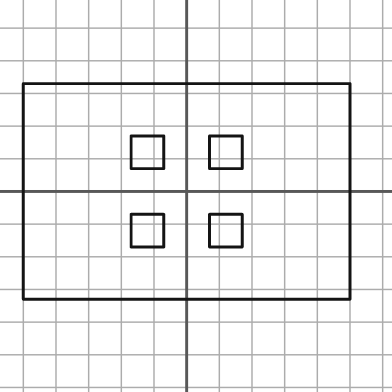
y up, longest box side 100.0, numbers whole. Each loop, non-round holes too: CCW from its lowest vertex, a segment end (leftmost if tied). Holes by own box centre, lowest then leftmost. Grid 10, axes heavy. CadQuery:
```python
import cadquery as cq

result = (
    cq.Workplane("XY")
    .moveTo(-50.0, -33.0)
    .lineTo(50.0, -33.0)
    .lineTo(50.0, 33.0)
    .lineTo(-50.0, 33.0)
    .close()
    .moveTo(-17.0, -17.0)
    .lineTo(-7.0, -17.0)
    .lineTo(-7.0, -7.0)
    .lineTo(-17.0, -7.0)
    .close()
    .moveTo(7.0, -17.0)
    .lineTo(17.0, -17.0)
    .lineTo(17.0, -7.0)
    .lineTo(7.0, -7.0)
    .close()
    .moveTo(-17.0, 7.0)
    .lineTo(-7.0, 7.0)
    .lineTo(-7.0, 17.0)
    .lineTo(-17.0, 17.0)
    .close()
    .moveTo(7.0, 7.0)
    .lineTo(17.0, 7.0)
    .lineTo(17.0, 17.0)
    .lineTo(7.0, 17.0)
    .close()
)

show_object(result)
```